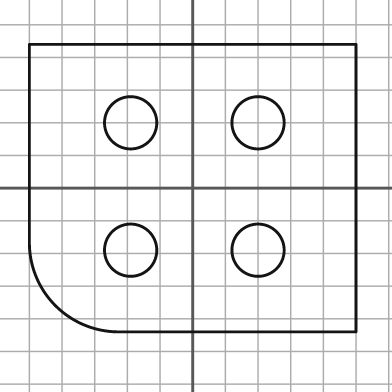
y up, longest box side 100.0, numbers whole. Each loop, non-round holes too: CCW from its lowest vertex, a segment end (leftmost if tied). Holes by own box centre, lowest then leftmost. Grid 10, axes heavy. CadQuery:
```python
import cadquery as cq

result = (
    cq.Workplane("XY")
    .moveTo(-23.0, -44.0)
    .lineTo(50.0, -44.0)
    .lineTo(50.0, 44.0)
    .lineTo(-50.0, 44.0)
    .lineTo(-50.0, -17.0)
    .threePointArc((-42.0, -36.0), (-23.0, -44.0))
    .close()
    .moveTo(-19.0, -19.0)
    .circle(8.0)
    .moveTo(20.0, -19.0)
    .circle(8.0)
    .moveTo(-19.0, 20.0)
    .circle(8.0)
    .moveTo(20.0, 20.0)
    .circle(8.0)
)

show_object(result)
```